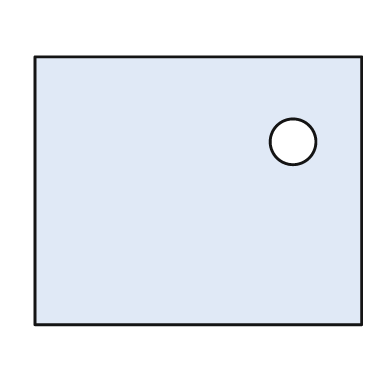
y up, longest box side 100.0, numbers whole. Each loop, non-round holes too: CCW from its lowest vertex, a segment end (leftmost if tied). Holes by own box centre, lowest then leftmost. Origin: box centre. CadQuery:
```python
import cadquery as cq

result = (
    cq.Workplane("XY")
    .moveTo(-50.0, -41.0)
    .lineTo(50.0, -41.0)
    .lineTo(50.0, 41.0)
    .lineTo(-50.0, 41.0)
    .close()
    .moveTo(29.0, 15.0)
    .circle(7.0)
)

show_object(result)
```